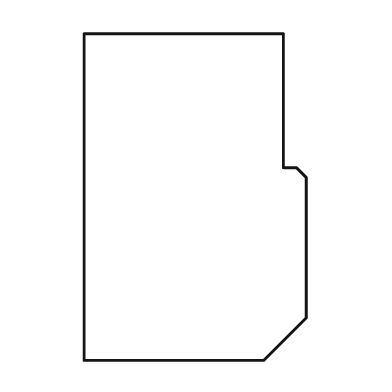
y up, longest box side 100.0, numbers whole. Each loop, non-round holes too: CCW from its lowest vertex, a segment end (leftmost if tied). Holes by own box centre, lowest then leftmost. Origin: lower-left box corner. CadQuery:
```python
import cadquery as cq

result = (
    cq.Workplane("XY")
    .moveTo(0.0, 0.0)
    .lineTo(55.0, 0.0)
    .lineTo(68.0, 13.0)
    .lineTo(68.0, 56.0)
    .lineTo(65.0, 59.0)
    .lineTo(61.0, 59.0)
    .lineTo(61.0, 100.0)
    .lineTo(0.0, 100.0)
    .close()
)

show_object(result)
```